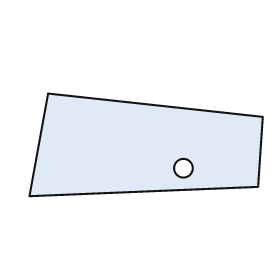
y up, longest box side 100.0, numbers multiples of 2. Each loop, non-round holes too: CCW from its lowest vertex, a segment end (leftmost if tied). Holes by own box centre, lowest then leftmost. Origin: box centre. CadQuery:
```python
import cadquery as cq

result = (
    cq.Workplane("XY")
    .moveTo(-50.0, -22.0)
    .lineTo(48.0, -18.0)
    .lineTo(50.0, 12.0)
    .lineTo(-42.0, 22.0)
    .close()
    .moveTo(16.0, -10.0)
    .circle(4.0)
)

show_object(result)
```